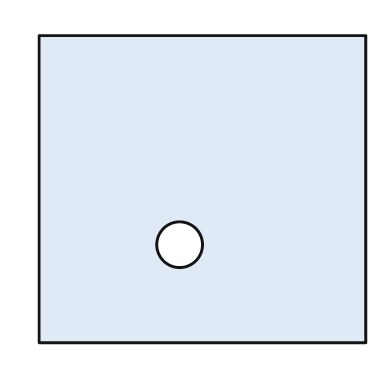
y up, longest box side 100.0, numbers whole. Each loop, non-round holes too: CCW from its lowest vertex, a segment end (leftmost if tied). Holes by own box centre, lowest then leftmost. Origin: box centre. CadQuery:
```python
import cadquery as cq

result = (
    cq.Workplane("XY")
    .moveTo(-50.0, -47.0)
    .lineTo(50.0, -47.0)
    .lineTo(50.0, 47.0)
    .lineTo(-50.0, 47.0)
    .close()
    .moveTo(-7.0, -17.0)
    .circle(7.0)
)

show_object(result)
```